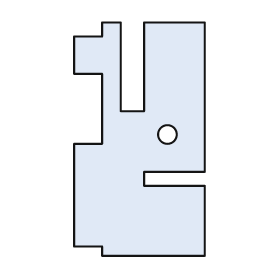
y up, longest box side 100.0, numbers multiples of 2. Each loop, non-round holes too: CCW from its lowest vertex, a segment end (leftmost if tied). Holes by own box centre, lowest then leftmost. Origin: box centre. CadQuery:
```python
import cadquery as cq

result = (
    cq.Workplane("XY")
    .moveTo(-16.0, -50.0)
    .lineTo(28.0, -50.0)
    .lineTo(28.0, -20.0)
    .lineTo(2.0, -20.0)
    .lineTo(2.0, -14.0)
    .lineTo(28.0, -14.0)
    .lineTo(28.0, 50.0)
    .lineTo(2.0, 50.0)
    .lineTo(2.0, 12.0)
    .lineTo(-8.0, 12.0)
    .lineTo(-8.0, 50.0)
    .lineTo(-16.0, 50.0)
    .lineTo(-16.0, 44.0)
    .lineTo(-28.0, 44.0)
    .lineTo(-28.0, 28.0)
    .lineTo(-16.0, 28.0)
    .lineTo(-16.0, -2.0)
    .lineTo(-28.0, -2.0)
    .lineTo(-28.0, -46.0)
    .lineTo(-16.0, -46.0)
    .close()
    .moveTo(12.0, 2.0)
    .circle(4.0)
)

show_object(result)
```